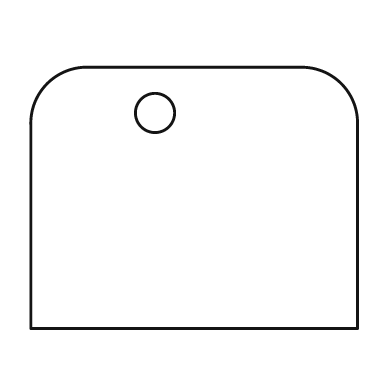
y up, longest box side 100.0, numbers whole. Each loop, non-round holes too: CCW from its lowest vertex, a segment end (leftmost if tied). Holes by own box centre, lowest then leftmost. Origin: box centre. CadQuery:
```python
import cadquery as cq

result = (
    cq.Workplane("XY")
    .moveTo(-50.0, -40.0)
    .lineTo(50.0, -40.0)
    .lineTo(50.0, 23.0)
    .threePointArc((45.0, 35.0), (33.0, 40.0))
    .lineTo(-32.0, 40.0)
    .threePointArc((-45.0, 35.0), (-50.0, 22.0))
    .close()
    .moveTo(-12.0, 26.0)
    .circle(6.0)
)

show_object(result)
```